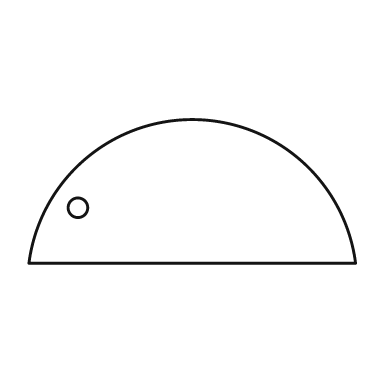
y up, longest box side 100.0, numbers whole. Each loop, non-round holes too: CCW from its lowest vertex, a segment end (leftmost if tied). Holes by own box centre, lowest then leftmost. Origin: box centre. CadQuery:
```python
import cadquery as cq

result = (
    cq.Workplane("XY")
    .moveTo(-50.0, -22.0)
    .lineTo(50.0, -22.0)
    .threePointArc((0.0, 22.0), (-50.0, -22.0))
    .close()
    .moveTo(-35.0, -5.0)
    .circle(3.0)
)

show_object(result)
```